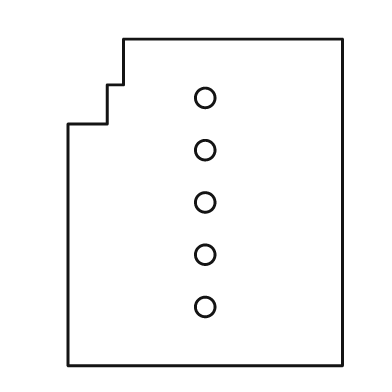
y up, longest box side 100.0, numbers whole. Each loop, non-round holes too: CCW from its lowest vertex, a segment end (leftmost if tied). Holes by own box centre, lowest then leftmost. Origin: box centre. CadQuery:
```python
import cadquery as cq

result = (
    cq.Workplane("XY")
    .moveTo(-42.0, -50.0)
    .lineTo(42.0, -50.0)
    .lineTo(42.0, 50.0)
    .lineTo(-25.0, 50.0)
    .lineTo(-25.0, 36.0)
    .lineTo(-30.0, 36.0)
    .lineTo(-30.0, 24.0)
    .lineTo(-42.0, 24.0)
    .close()
    .moveTo(0.0, -32.0)
    .circle(3.0)
    .moveTo(0.0, -16.0)
    .circle(3.0)
    .moveTo(0.0, 0.0)
    .circle(3.0)
    .moveTo(0.0, 16.0)
    .circle(3.0)
    .moveTo(0.0, 32.0)
    .circle(3.0)
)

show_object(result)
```